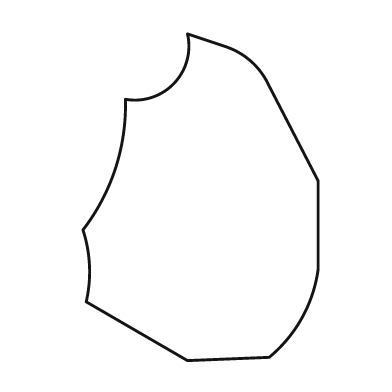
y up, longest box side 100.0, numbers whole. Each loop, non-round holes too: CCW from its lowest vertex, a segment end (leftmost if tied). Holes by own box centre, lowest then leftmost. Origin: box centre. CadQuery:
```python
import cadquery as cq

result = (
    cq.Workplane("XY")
    .moveTo(-4.0, -50.0)
    .lineTo(21.0, -49.0)
    .threePointArc((31.0, -37.0), (36.0, -22.0))
    .lineTo(36.0, 5.0)
    .lineTo(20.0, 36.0)
    .threePointArc((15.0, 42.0), (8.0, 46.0))
    .lineTo(-4.0, 50.0)
    .threePointArc((-8.0, 35.0), (-23.0, 30.0))
    .threePointArc((-26.0, 9.0), (-36.0, -10.0))
    .threePointArc((-34.0, -21.0), (-35.0, -32.0))
    .close()
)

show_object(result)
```